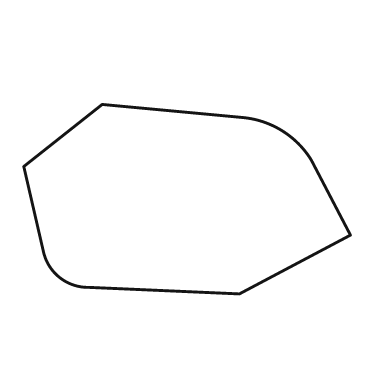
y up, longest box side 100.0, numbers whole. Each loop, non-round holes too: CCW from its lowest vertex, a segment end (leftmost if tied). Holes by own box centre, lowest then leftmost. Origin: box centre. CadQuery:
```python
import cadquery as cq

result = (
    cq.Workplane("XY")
    .moveTo(16.0, -29.0)
    .lineTo(50.0, -11.0)
    .lineTo(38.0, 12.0)
    .threePointArc((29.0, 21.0), (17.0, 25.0))
    .lineTo(-26.0, 29.0)
    .lineTo(-50.0, 10.0)
    .lineTo(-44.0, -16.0)
    .threePointArc((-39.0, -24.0), (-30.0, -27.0))
    .close()
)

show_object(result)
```